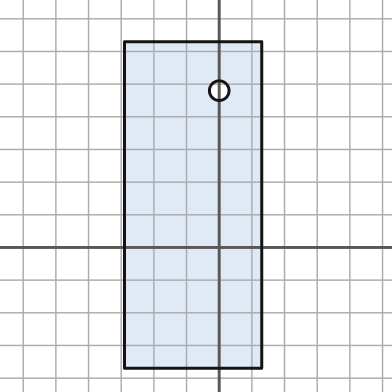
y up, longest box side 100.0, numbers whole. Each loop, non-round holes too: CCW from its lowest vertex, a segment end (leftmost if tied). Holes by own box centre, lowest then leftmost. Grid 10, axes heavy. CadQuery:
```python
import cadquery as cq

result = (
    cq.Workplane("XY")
    .moveTo(-29.0, -37.0)
    .lineTo(13.0, -37.0)
    .lineTo(13.0, 63.0)
    .lineTo(-29.0, 63.0)
    .close()
    .moveTo(0.0, 48.0)
    .circle(3.0)
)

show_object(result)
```